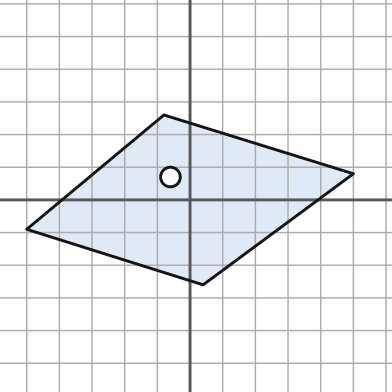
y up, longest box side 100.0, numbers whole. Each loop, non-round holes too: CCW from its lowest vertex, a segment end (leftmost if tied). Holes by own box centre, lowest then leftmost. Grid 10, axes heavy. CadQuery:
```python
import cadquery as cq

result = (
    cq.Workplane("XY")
    .moveTo(4.0, -26.0)
    .lineTo(50.0, 8.0)
    .lineTo(-8.0, 26.0)
    .lineTo(-50.0, -9.0)
    .close()
    .moveTo(-6.0, 7.0)
    .circle(3.0)
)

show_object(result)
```